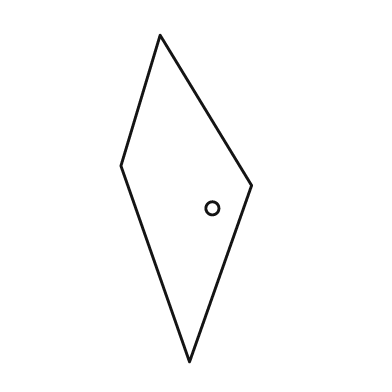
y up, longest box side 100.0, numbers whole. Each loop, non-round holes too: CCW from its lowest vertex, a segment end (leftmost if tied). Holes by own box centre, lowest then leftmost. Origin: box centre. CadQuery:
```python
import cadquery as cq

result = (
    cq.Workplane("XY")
    .moveTo(1.0, -50.0)
    .lineTo(20.0, 4.0)
    .lineTo(-8.0, 50.0)
    .lineTo(-20.0, 10.0)
    .close()
    .moveTo(8.0, -3.0)
    .circle(2.0)
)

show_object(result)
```